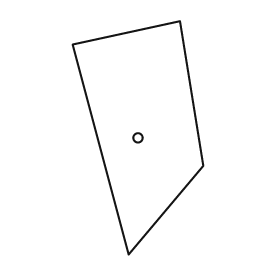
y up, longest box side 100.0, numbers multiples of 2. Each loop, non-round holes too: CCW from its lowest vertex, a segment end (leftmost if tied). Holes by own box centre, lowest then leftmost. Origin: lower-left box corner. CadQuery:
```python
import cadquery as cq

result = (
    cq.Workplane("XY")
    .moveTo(24.0, 0.0)
    .lineTo(56.0, 38.0)
    .lineTo(46.0, 100.0)
    .lineTo(0.0, 90.0)
    .close()
    .moveTo(28.0, 50.0)
    .circle(2.0)
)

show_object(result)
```